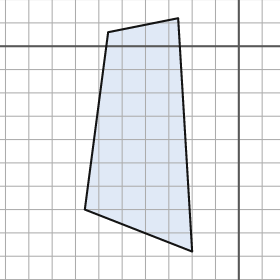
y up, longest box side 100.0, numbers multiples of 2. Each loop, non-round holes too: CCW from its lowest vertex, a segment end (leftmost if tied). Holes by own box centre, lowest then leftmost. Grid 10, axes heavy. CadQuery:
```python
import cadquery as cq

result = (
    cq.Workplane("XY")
    .moveTo(-20.0, -88.0)
    .lineTo(-26.0, 12.0)
    .lineTo(-56.0, 6.0)
    .lineTo(-66.0, -70.0)
    .close()
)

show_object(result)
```